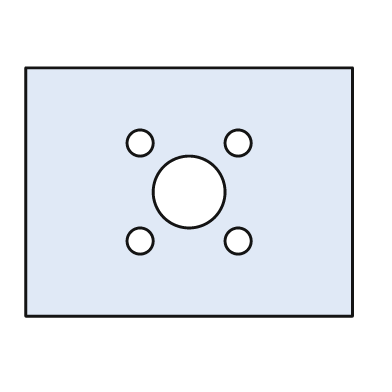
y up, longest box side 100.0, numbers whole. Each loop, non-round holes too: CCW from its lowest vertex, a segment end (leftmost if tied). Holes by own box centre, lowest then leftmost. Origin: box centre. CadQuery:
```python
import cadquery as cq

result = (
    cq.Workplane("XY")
    .moveTo(-50.0, -38.0)
    .lineTo(50.0, -38.0)
    .lineTo(50.0, 38.0)
    .lineTo(-50.0, 38.0)
    .close()
    .moveTo(-15.0, -15.0)
    .circle(4.0)
    .moveTo(15.0, -15.0)
    .circle(4.0)
    .moveTo(0.0, 0.0)
    .circle(11.0)
    .moveTo(-15.0, 15.0)
    .circle(4.0)
    .moveTo(15.0, 15.0)
    .circle(4.0)
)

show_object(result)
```